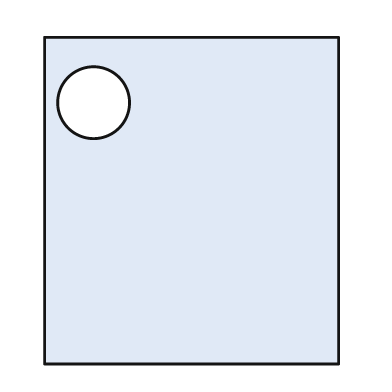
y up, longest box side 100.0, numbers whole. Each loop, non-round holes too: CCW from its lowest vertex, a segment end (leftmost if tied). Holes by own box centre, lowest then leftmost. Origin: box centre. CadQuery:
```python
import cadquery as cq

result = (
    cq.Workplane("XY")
    .moveTo(-45.0, -50.0)
    .lineTo(45.0, -50.0)
    .lineTo(45.0, 50.0)
    .lineTo(-45.0, 50.0)
    .close()
    .moveTo(-30.0, 30.0)
    .circle(11.0)
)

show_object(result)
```